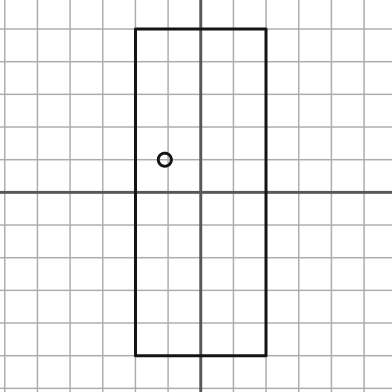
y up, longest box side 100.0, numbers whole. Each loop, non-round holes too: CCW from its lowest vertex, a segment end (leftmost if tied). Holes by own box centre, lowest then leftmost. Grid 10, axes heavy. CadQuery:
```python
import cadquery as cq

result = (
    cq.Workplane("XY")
    .moveTo(-20.0, -50.0)
    .lineTo(20.0, -50.0)
    .lineTo(20.0, 50.0)
    .lineTo(-20.0, 50.0)
    .close()
    .moveTo(-11.0, 10.0)
    .circle(2.0)
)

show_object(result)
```